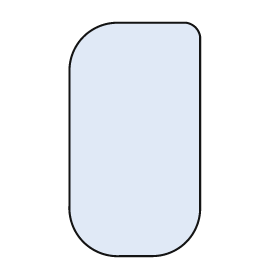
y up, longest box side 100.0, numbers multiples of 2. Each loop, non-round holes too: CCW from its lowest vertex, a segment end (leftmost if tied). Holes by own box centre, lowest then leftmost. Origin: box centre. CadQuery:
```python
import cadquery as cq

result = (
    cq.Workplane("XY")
    .moveTo(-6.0, -50.0)
    .lineTo(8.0, -50.0)
    .threePointArc((22.0, -44.0), (28.0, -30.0))
    .lineTo(28.0, 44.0)
    .threePointArc((26.0, 48.0), (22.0, 50.0))
    .lineTo(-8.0, 50.0)
    .threePointArc((-22.0, 44.0), (-28.0, 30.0))
    .lineTo(-28.0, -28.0)
    .threePointArc((-22.0, -44.0), (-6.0, -50.0))
    .close()
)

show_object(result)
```